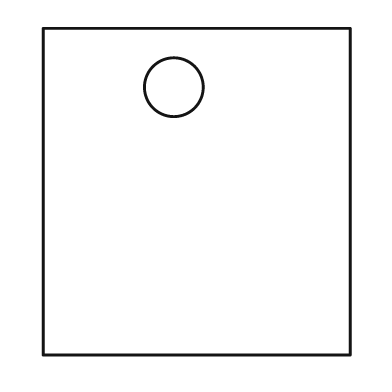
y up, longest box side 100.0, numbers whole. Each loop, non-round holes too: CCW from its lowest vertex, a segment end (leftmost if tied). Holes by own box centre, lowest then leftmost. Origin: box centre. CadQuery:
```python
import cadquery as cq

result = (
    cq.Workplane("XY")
    .moveTo(-47.0, -50.0)
    .lineTo(47.0, -50.0)
    .lineTo(47.0, 50.0)
    .lineTo(-47.0, 50.0)
    .close()
    .moveTo(-7.0, 32.0)
    .circle(9.0)
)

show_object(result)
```